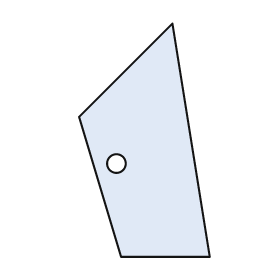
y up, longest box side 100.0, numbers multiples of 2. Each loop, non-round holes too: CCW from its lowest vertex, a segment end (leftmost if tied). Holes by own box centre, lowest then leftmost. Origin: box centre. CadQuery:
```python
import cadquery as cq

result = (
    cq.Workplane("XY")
    .moveTo(-10.0, -50.0)
    .lineTo(28.0, -50.0)
    .lineTo(12.0, 50.0)
    .lineTo(-28.0, 10.0)
    .close()
    .moveTo(-12.0, -10.0)
    .circle(4.0)
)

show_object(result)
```